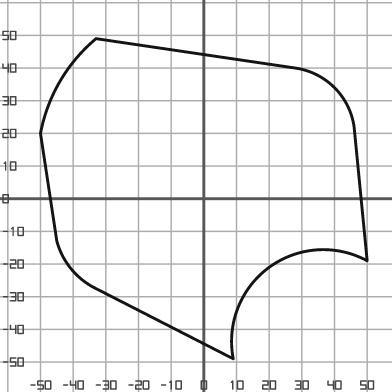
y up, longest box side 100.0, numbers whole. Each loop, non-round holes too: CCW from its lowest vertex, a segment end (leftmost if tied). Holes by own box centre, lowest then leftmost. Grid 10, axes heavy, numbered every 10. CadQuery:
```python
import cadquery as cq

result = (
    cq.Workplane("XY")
    .moveTo(9.0, -49.0)
    .threePointArc((20.0, -21.0), (50.0, -19.0))
    .lineTo(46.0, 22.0)
    .threePointArc((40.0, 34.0), (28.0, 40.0))
    .lineTo(-33.0, 49.0)
    .threePointArc((-44.0, 36.0), (-50.0, 20.0))
    .lineTo(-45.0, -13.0)
    .threePointArc((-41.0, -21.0), (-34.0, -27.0))
    .close()
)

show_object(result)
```